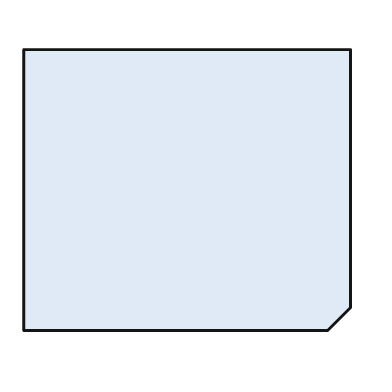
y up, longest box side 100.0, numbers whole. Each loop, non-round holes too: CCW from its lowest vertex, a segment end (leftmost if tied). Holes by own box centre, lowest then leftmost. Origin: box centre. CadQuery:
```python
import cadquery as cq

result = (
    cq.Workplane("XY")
    .moveTo(-50.0, -43.0)
    .lineTo(43.0, -43.0)
    .lineTo(50.0, -36.0)
    .lineTo(50.0, 43.0)
    .lineTo(-50.0, 43.0)
    .close()
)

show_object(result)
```